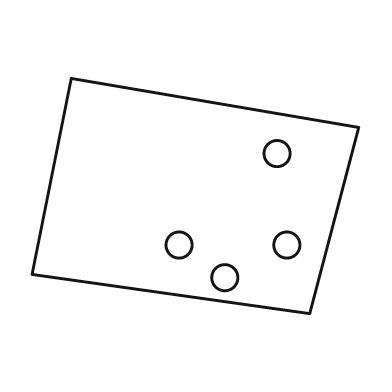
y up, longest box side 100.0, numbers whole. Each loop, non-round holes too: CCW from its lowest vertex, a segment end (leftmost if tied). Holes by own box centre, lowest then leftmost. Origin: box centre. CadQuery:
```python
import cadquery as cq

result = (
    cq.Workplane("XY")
    .moveTo(35.0, -36.0)
    .lineTo(50.0, 21.0)
    .lineTo(-38.0, 36.0)
    .lineTo(-50.0, -24.0)
    .close()
    .moveTo(9.0, -25.0)
    .circle(4.0)
    .moveTo(-5.0, -15.0)
    .circle(4.0)
    .moveTo(28.0, -15.0)
    .circle(4.0)
    .moveTo(25.0, 13.0)
    .circle(4.0)
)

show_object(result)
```